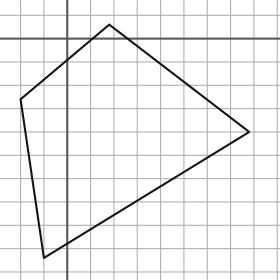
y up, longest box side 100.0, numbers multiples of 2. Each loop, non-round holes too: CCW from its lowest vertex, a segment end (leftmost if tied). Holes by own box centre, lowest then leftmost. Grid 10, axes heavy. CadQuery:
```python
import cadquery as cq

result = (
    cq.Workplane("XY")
    .moveTo(-10.0, -94.0)
    .lineTo(78.0, -40.0)
    .lineTo(18.0, 6.0)
    .lineTo(-20.0, -26.0)
    .close()
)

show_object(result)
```